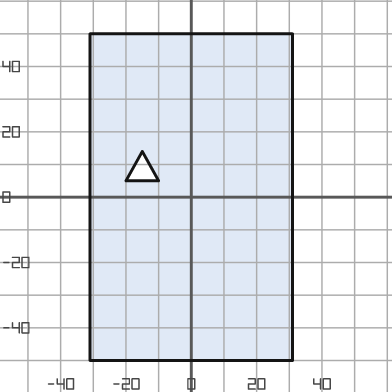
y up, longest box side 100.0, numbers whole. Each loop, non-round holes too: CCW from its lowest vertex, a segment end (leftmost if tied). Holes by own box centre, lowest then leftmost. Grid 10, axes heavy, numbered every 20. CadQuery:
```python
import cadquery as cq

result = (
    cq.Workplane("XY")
    .moveTo(-31.0, -50.0)
    .lineTo(31.0, -50.0)
    .lineTo(31.0, 50.0)
    .lineTo(-31.0, 50.0)
    .close()
    .moveTo(-20.0, 5.0)
    .lineTo(-10.0, 5.0)
    .lineTo(-15.0, 14.0)
    .close()
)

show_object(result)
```